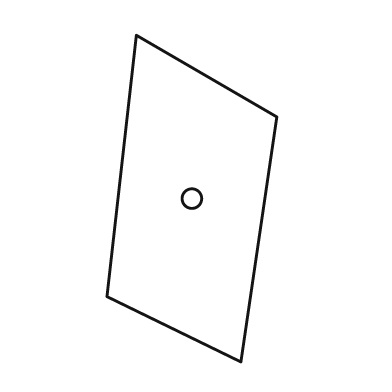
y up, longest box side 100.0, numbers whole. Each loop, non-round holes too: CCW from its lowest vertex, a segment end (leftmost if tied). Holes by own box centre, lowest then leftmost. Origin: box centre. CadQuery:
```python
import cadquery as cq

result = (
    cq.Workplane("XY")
    .moveTo(15.0, -50.0)
    .lineTo(26.0, 25.0)
    .lineTo(-17.0, 50.0)
    .lineTo(-26.0, -30.0)
    .close()
    .moveTo(0.0, 0.0)
    .circle(3.0)
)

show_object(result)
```